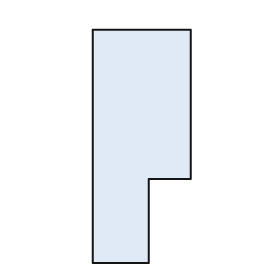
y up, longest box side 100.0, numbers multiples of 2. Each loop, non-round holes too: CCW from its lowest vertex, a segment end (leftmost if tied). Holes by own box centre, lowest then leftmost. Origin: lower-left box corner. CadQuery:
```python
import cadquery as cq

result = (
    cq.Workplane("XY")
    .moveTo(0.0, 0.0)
    .lineTo(24.0, 0.0)
    .lineTo(24.0, 36.0)
    .lineTo(42.0, 36.0)
    .lineTo(42.0, 100.0)
    .lineTo(0.0, 100.0)
    .close()
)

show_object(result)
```